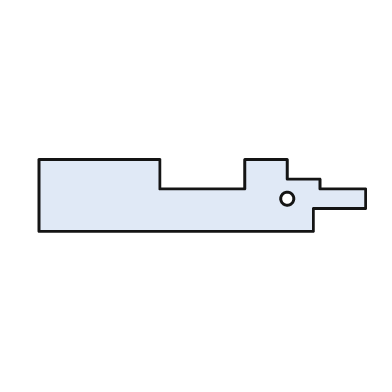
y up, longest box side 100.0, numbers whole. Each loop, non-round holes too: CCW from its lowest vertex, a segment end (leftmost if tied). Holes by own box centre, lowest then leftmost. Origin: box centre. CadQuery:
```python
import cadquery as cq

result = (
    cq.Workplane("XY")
    .moveTo(-50.0, -11.0)
    .lineTo(34.0, -11.0)
    .lineTo(34.0, -4.0)
    .lineTo(50.0, -4.0)
    .lineTo(50.0, 2.0)
    .lineTo(36.0, 2.0)
    .lineTo(36.0, 5.0)
    .lineTo(26.0, 5.0)
    .lineTo(26.0, 11.0)
    .lineTo(13.0, 11.0)
    .lineTo(13.0, 2.0)
    .lineTo(-13.0, 2.0)
    .lineTo(-13.0, 11.0)
    .lineTo(-50.0, 11.0)
    .close()
    .moveTo(26.0, -1.0)
    .circle(2.0)
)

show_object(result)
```